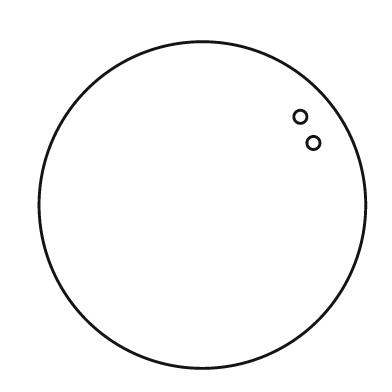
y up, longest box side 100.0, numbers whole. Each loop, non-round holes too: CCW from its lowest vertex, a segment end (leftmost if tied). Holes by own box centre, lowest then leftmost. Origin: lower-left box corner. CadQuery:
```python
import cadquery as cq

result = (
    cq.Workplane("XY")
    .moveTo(50.0, 50.0)
    .circle(50.0)
    .moveTo(84.0, 69.0)
    .circle(2.0)
    .moveTo(80.0, 77.0)
    .circle(2.0)
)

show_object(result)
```